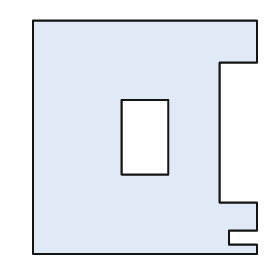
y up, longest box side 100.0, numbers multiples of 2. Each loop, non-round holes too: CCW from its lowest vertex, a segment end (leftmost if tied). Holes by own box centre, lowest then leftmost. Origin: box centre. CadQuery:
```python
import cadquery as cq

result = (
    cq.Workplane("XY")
    .moveTo(-48.0, -50.0)
    .lineTo(48.0, -50.0)
    .lineTo(48.0, -46.0)
    .lineTo(36.0, -46.0)
    .lineTo(36.0, -40.0)
    .lineTo(48.0, -40.0)
    .lineTo(48.0, -28.0)
    .lineTo(32.0, -28.0)
    .lineTo(32.0, 32.0)
    .lineTo(48.0, 32.0)
    .lineTo(48.0, 50.0)
    .lineTo(-48.0, 50.0)
    .close()
    .moveTo(-10.0, -16.0)
    .lineTo(10.0, -16.0)
    .lineTo(10.0, 16.0)
    .lineTo(-10.0, 16.0)
    .close()
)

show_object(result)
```